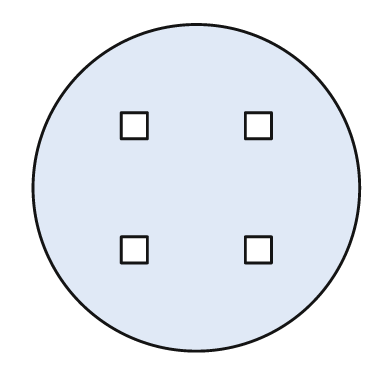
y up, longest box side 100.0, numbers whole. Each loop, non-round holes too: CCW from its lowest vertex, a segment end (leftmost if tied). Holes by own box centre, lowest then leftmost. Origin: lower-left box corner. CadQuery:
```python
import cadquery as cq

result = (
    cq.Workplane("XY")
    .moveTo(50.0, 50.0)
    .circle(50.0)
    .moveTo(27.0, 27.0)
    .lineTo(35.0, 27.0)
    .lineTo(35.0, 35.0)
    .lineTo(27.0, 35.0)
    .close()
    .moveTo(65.0, 27.0)
    .lineTo(73.0, 27.0)
    .lineTo(73.0, 35.0)
    .lineTo(65.0, 35.0)
    .close()
    .moveTo(27.0, 65.0)
    .lineTo(35.0, 65.0)
    .lineTo(35.0, 73.0)
    .lineTo(27.0, 73.0)
    .close()
    .moveTo(65.0, 65.0)
    .lineTo(73.0, 65.0)
    .lineTo(73.0, 73.0)
    .lineTo(65.0, 73.0)
    .close()
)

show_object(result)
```